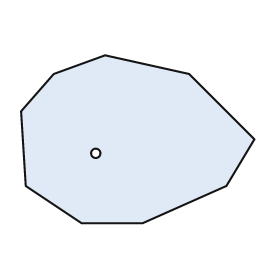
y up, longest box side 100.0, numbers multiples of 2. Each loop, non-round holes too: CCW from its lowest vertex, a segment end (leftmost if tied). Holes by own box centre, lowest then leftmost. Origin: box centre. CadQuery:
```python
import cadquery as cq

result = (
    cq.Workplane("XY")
    .moveTo(-24.0, -36.0)
    .lineTo(2.0, -36.0)
    .lineTo(38.0, -20.0)
    .lineTo(50.0, 0.0)
    .lineTo(22.0, 28.0)
    .lineTo(-14.0, 36.0)
    .lineTo(-36.0, 28.0)
    .lineTo(-50.0, 12.0)
    .lineTo(-48.0, -20.0)
    .close()
    .moveTo(-18.0, -6.0)
    .circle(2.0)
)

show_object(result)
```